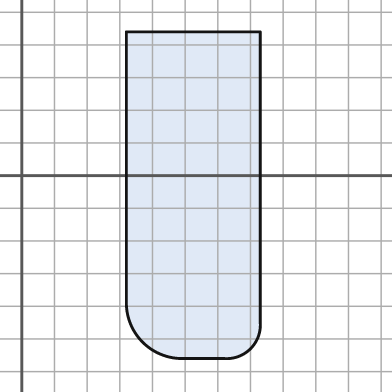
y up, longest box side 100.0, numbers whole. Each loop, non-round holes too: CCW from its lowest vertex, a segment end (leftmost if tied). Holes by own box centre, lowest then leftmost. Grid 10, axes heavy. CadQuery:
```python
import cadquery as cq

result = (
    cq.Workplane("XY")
    .moveTo(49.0, -56.0)
    .lineTo(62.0, -56.0)
    .threePointArc((70.0, -53.0), (73.0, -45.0))
    .lineTo(73.0, 44.0)
    .lineTo(32.0, 44.0)
    .lineTo(32.0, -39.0)
    .threePointArc((37.0, -51.0), (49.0, -56.0))
    .close()
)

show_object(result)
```